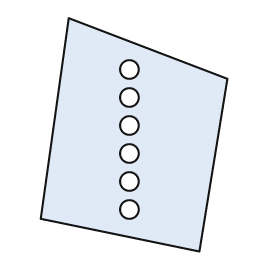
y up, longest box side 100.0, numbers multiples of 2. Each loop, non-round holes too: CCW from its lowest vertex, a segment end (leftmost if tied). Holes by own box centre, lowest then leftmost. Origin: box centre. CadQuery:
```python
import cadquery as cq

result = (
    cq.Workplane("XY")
    .moveTo(28.0, -50.0)
    .lineTo(40.0, 24.0)
    .lineTo(-28.0, 50.0)
    .lineTo(-40.0, -36.0)
    .close()
    .moveTo(-2.0, -32.0)
    .circle(4.0)
    .moveTo(-2.0, -20.0)
    .circle(4.0)
    .moveTo(-2.0, -8.0)
    .circle(4.0)
    .moveTo(-2.0, 4.0)
    .circle(4.0)
    .moveTo(-2.0, 16.0)
    .circle(4.0)
    .moveTo(-2.0, 28.0)
    .circle(4.0)
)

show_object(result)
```